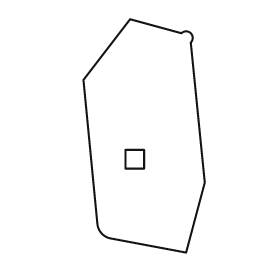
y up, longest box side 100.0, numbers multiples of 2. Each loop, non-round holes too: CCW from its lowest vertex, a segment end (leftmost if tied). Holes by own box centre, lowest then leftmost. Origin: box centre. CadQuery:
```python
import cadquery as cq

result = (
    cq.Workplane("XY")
    .moveTo(18.0, -50.0)
    .lineTo(26.0, -20.0)
    .lineTo(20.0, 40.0)
    .threePointArc((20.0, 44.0), (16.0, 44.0))
    .lineTo(-6.0, 50.0)
    .lineTo(-26.0, 24.0)
    .lineTo(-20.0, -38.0)
    .threePointArc((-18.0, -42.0), (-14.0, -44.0))
    .close()
    .moveTo(-8.0, -14.0)
    .lineTo(0.0, -14.0)
    .lineTo(0.0, -6.0)
    .lineTo(-8.0, -6.0)
    .close()
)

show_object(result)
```